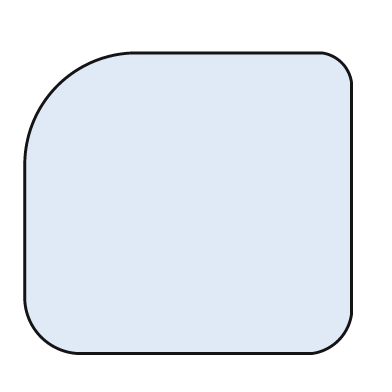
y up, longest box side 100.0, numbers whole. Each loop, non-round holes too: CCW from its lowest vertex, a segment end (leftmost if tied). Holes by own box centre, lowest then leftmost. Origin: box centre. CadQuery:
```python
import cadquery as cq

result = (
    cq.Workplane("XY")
    .moveTo(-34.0, -46.0)
    .lineTo(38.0, -46.0)
    .threePointArc((46.0, -42.0), (50.0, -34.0))
    .lineTo(50.0, 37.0)
    .threePointArc((47.0, 43.0), (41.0, 46.0))
    .lineTo(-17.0, 46.0)
    .threePointArc((-40.0, 36.0), (-50.0, 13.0))
    .lineTo(-50.0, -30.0)
    .threePointArc((-45.0, -41.0), (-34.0, -46.0))
    .close()
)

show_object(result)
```